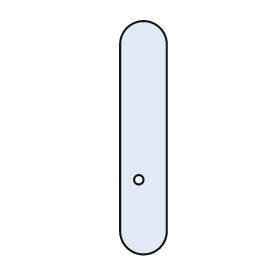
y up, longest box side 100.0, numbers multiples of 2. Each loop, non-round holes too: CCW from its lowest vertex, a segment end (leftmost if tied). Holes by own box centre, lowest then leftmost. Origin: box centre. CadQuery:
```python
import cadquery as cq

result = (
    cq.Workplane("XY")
    .moveTo(-10.0, -40.0)
    .threePointArc((0.0, -50.0), (10.0, -40.0))
    .lineTo(10.0, 40.0)
    .threePointArc((0.0, 50.0), (-10.0, 40.0))
    .close()
    .moveTo(-2.0, -18.0)
    .circle(2.0)
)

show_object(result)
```